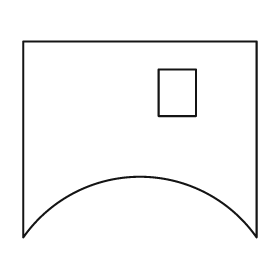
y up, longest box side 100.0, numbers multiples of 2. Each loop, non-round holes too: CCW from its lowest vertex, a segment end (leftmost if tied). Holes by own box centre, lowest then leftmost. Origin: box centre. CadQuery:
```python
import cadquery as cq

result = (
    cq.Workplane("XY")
    .moveTo(-50.0, -42.0)
    .threePointArc((0.0, -16.0), (50.0, -42.0))
    .lineTo(50.0, 42.0)
    .lineTo(-50.0, 42.0)
    .close()
    .moveTo(8.0, 10.0)
    .lineTo(24.0, 10.0)
    .lineTo(24.0, 30.0)
    .lineTo(8.0, 30.0)
    .close()
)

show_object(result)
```